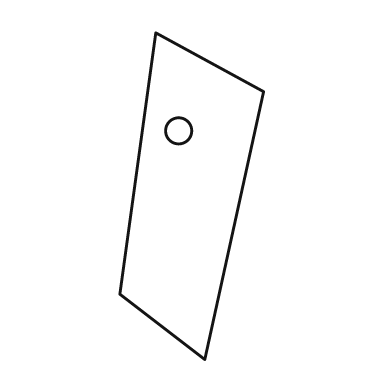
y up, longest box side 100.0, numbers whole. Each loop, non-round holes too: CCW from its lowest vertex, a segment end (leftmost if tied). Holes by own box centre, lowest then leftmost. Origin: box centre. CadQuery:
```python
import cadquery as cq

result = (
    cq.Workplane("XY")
    .moveTo(4.0, -50.0)
    .lineTo(22.0, 32.0)
    .lineTo(-11.0, 50.0)
    .lineTo(-22.0, -30.0)
    .close()
    .moveTo(-4.0, 20.0)
    .circle(4.0)
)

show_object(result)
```